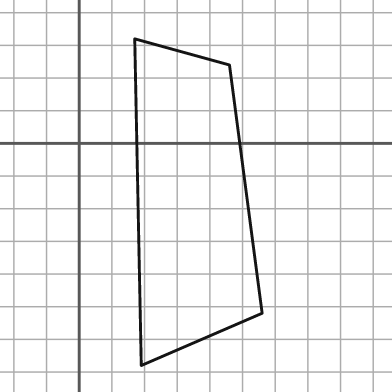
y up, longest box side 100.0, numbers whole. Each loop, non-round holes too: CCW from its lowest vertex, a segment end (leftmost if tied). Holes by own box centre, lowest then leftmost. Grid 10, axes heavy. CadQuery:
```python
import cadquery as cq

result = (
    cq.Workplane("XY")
    .moveTo(19.0, -68.0)
    .lineTo(56.0, -52.0)
    .lineTo(46.0, 24.0)
    .lineTo(17.0, 32.0)
    .close()
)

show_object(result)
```